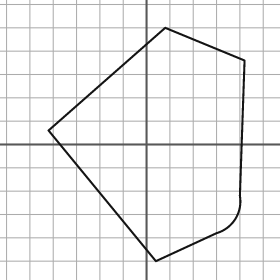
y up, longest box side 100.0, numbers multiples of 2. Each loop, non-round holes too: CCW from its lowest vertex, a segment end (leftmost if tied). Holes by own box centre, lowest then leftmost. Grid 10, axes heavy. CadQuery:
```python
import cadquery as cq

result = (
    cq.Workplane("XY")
    .moveTo(4.0, -50.0)
    .lineTo(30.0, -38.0)
    .threePointArc((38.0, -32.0), (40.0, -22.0))
    .lineTo(42.0, 36.0)
    .lineTo(8.0, 50.0)
    .lineTo(-42.0, 6.0)
    .close()
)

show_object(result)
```